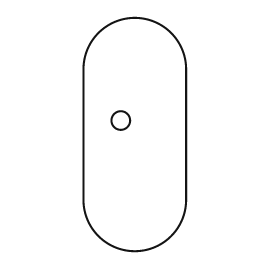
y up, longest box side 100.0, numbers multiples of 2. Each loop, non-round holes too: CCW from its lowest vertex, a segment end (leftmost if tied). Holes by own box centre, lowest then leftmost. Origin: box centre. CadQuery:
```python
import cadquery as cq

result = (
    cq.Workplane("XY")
    .moveTo(-22.0, -28.0)
    .threePointArc((0.0, -50.0), (22.0, -28.0))
    .lineTo(22.0, 28.0)
    .threePointArc((0.0, 50.0), (-22.0, 28.0))
    .close()
    .moveTo(-6.0, 6.0)
    .circle(4.0)
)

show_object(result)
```